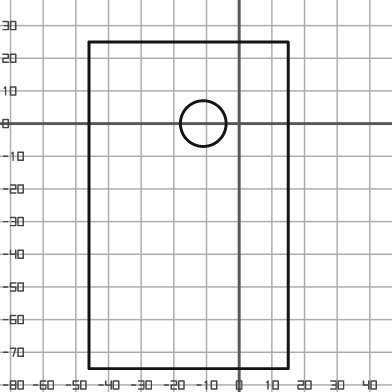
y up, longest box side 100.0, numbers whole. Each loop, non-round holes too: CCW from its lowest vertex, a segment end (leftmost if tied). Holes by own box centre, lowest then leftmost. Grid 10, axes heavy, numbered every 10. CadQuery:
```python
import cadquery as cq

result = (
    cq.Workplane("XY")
    .moveTo(-46.0, -75.0)
    .lineTo(15.0, -75.0)
    .lineTo(15.0, 25.0)
    .lineTo(-46.0, 25.0)
    .close()
    .moveTo(-11.0, 0.0)
    .circle(7.0)
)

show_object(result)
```